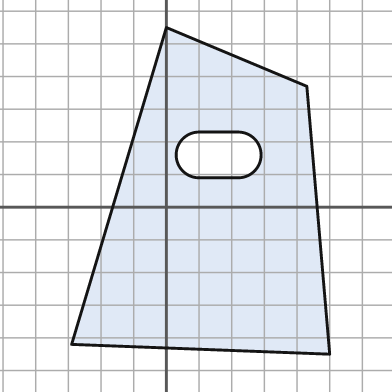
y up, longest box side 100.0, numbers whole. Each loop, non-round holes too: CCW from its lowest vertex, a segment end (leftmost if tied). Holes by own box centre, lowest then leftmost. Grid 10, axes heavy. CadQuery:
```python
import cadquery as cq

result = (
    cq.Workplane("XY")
    .moveTo(50.0, -45.0)
    .lineTo(43.0, 37.0)
    .lineTo(0.0, 55.0)
    .lineTo(-29.0, -42.0)
    .close()
    .moveTo(10.0, 9.0)
    .lineTo(22.0, 9.0)
    .threePointArc((29.0, 16.0), (22.0, 23.0))
    .lineTo(10.0, 23.0)
    .threePointArc((3.0, 16.0), (10.0, 9.0))
    .close()
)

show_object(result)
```